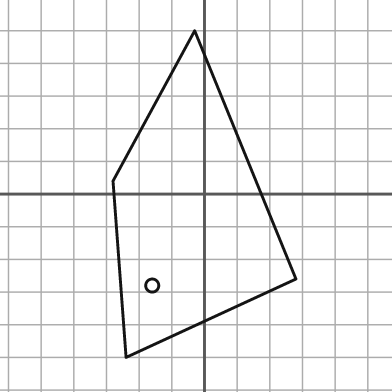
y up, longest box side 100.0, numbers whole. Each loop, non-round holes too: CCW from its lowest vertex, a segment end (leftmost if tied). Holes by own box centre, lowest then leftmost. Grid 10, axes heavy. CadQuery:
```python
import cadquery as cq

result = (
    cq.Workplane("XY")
    .moveTo(-24.0, -50.0)
    .lineTo(28.0, -26.0)
    .lineTo(-3.0, 50.0)
    .lineTo(-28.0, 4.0)
    .close()
    .moveTo(-16.0, -28.0)
    .circle(2.0)
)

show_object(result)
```